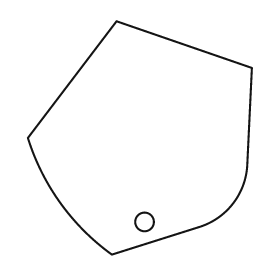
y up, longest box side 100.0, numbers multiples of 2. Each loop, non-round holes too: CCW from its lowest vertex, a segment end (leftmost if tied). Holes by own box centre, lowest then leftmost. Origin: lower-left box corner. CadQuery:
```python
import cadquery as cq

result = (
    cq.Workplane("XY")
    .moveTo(36.0, 0.0)
    .lineTo(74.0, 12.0)
    .threePointArc((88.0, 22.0), (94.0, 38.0))
    .lineTo(96.0, 80.0)
    .lineTo(38.0, 100.0)
    .lineTo(0.0, 50.0)
    .threePointArc((14.0, 22.0), (36.0, 0.0))
    .close()
    .moveTo(50.0, 14.0)
    .circle(4.0)
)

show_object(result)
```